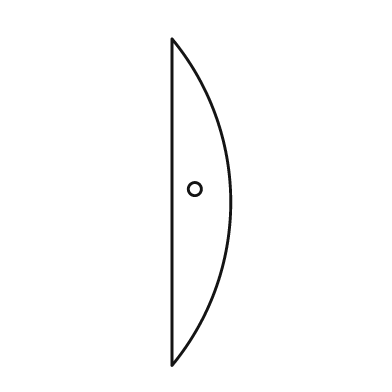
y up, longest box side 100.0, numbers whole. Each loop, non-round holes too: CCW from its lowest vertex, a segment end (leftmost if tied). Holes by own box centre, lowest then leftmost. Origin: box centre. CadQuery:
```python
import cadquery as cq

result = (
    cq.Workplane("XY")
    .moveTo(-9.0, -50.0)
    .threePointArc((9.0, 0.0), (-9.0, 50.0))
    .close()
    .moveTo(-2.0, 4.0)
    .circle(2.0)
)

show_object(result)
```